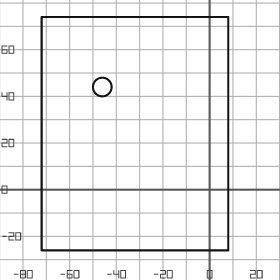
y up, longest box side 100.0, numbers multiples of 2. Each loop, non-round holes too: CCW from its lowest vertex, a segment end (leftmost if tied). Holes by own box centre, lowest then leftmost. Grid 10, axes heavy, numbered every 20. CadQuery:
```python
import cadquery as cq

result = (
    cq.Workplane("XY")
    .moveTo(-72.0, -26.0)
    .lineTo(8.0, -26.0)
    .lineTo(8.0, 74.0)
    .lineTo(-72.0, 74.0)
    .close()
    .moveTo(-46.0, 44.0)
    .circle(4.0)
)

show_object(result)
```